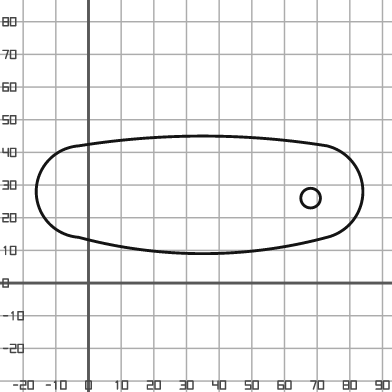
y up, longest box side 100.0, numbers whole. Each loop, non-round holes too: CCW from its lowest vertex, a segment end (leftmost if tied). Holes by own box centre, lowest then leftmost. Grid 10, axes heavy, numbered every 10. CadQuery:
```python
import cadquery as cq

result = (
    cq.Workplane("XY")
    .moveTo(-3.0, 14.0)
    .threePointArc((35.0, 9.0), (73.0, 14.0))
    .threePointArc((84.0, 28.0), (73.0, 42.0))
    .threePointArc((35.0, 45.0), (-3.0, 42.0))
    .threePointArc((-16.0, 28.0), (-3.0, 14.0))
    .close()
    .moveTo(68.0, 26.0)
    .circle(3.0)
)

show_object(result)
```